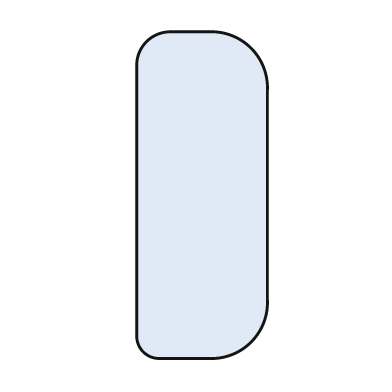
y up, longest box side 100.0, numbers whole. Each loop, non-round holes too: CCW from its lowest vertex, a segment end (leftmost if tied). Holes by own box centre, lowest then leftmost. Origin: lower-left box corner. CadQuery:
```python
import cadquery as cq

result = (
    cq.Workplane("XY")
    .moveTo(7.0, 0.0)
    .lineTo(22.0, 0.0)
    .threePointArc((35.0, 5.0), (40.0, 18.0))
    .lineTo(40.0, 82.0)
    .threePointArc((35.0, 95.0), (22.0, 100.0))
    .lineTo(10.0, 100.0)
    .threePointArc((3.0, 97.0), (0.0, 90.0))
    .lineTo(0.0, 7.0)
    .threePointArc((2.0, 2.0), (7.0, 0.0))
    .close()
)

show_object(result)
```